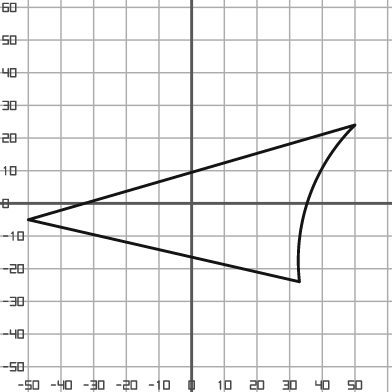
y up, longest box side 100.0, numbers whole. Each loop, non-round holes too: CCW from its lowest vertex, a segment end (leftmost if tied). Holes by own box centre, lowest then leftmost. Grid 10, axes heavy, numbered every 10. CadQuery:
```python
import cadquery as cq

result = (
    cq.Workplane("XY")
    .moveTo(33.0, -24.0)
    .threePointArc((36.0, 2.0), (50.0, 24.0))
    .lineTo(-50.0, -5.0)
    .close()
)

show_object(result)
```